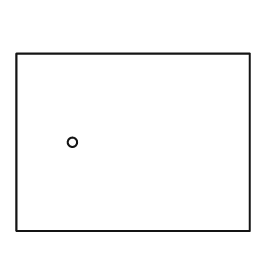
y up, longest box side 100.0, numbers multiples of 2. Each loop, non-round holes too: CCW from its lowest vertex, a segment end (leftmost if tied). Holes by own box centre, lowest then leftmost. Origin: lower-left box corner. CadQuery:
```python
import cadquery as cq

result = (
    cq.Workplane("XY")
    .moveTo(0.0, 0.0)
    .lineTo(100.0, 0.0)
    .lineTo(100.0, 76.0)
    .lineTo(0.0, 76.0)
    .close()
    .moveTo(24.0, 38.0)
    .circle(2.0)
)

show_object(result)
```